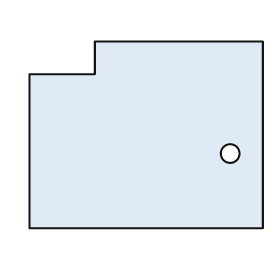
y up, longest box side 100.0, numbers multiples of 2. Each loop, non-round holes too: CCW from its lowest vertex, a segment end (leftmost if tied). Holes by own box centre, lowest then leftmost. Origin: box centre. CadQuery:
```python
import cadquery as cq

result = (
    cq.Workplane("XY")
    .moveTo(-50.0, -40.0)
    .lineTo(50.0, -40.0)
    .lineTo(50.0, 40.0)
    .lineTo(-22.0, 40.0)
    .lineTo(-22.0, 26.0)
    .lineTo(-50.0, 26.0)
    .close()
    .moveTo(36.0, -8.0)
    .circle(4.0)
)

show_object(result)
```